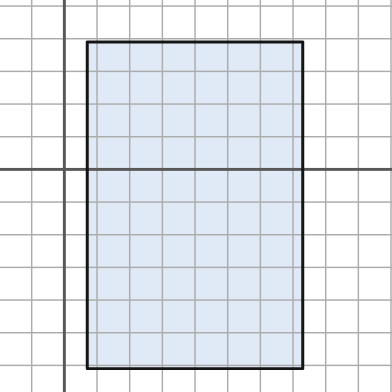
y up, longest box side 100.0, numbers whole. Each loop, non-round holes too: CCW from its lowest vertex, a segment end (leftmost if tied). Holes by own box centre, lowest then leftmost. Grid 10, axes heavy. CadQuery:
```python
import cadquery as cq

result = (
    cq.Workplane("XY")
    .moveTo(7.0, -61.0)
    .lineTo(73.0, -61.0)
    .lineTo(73.0, 39.0)
    .lineTo(7.0, 39.0)
    .close()
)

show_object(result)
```